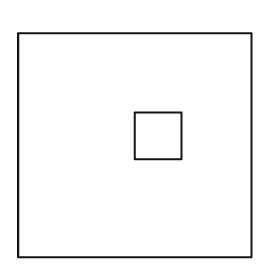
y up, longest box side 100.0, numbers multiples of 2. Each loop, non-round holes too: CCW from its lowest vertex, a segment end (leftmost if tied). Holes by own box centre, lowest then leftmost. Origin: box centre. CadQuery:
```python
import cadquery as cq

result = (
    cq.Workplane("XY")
    .moveTo(-50.0, -48.0)
    .lineTo(50.0, -48.0)
    .lineTo(50.0, 48.0)
    .lineTo(-50.0, 48.0)
    .close()
    .moveTo(0.0, -6.0)
    .lineTo(20.0, -6.0)
    .lineTo(20.0, 14.0)
    .lineTo(0.0, 14.0)
    .close()
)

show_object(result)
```